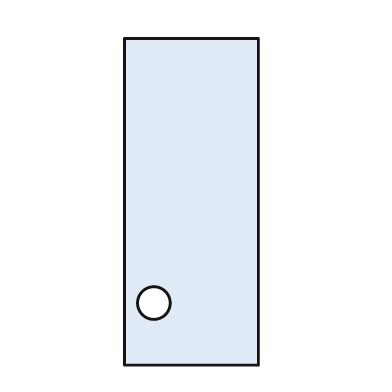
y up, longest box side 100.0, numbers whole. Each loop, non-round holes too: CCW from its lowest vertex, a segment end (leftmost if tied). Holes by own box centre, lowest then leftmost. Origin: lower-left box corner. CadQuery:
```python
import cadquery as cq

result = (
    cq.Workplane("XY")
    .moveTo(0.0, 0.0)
    .lineTo(41.0, 0.0)
    .lineTo(41.0, 100.0)
    .lineTo(0.0, 100.0)
    .close()
    .moveTo(9.0, 19.0)
    .circle(5.0)
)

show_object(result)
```